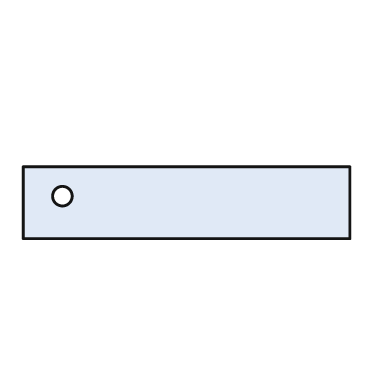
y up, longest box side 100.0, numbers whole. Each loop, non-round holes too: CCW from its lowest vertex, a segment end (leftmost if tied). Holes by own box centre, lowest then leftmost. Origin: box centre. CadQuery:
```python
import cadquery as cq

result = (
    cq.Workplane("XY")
    .moveTo(-50.0, -11.0)
    .lineTo(50.0, -11.0)
    .lineTo(50.0, 11.0)
    .lineTo(-50.0, 11.0)
    .close()
    .moveTo(-38.0, 2.0)
    .circle(3.0)
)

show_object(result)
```